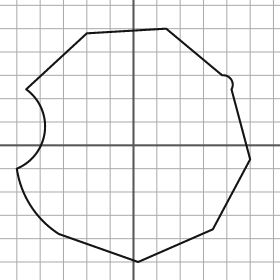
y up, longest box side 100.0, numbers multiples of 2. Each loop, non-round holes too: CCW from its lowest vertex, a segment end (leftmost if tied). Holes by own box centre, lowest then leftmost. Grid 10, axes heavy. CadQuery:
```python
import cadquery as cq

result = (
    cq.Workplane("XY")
    .moveTo(2.0, -50.0)
    .lineTo(34.0, -36.0)
    .lineTo(50.0, -6.0)
    .lineTo(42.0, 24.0)
    .threePointArc((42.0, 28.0), (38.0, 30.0))
    .lineTo(14.0, 50.0)
    .lineTo(-20.0, 48.0)
    .lineTo(-46.0, 24.0)
    .threePointArc((-38.0, 6.0), (-50.0, -10.0))
    .threePointArc((-44.0, -26.0), (-32.0, -38.0))
    .close()
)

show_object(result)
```